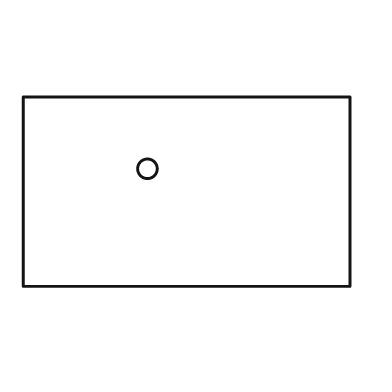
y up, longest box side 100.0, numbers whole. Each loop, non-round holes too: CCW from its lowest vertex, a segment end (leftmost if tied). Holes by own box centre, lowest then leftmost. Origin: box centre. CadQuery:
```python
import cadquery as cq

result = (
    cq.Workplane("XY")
    .moveTo(-50.0, -29.0)
    .lineTo(50.0, -29.0)
    .lineTo(50.0, 29.0)
    .lineTo(-50.0, 29.0)
    .close()
    .moveTo(-12.0, 7.0)
    .circle(3.0)
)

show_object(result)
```